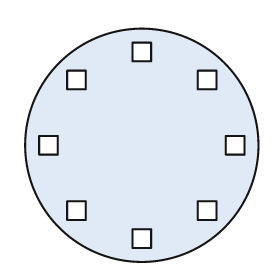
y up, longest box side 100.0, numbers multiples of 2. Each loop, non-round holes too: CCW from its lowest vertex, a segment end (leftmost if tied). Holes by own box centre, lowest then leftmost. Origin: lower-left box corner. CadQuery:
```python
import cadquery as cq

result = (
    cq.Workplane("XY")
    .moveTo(50.0, 50.0)
    .circle(50.0)
    .moveTo(46.0, 6.0)
    .lineTo(54.0, 6.0)
    .lineTo(54.0, 14.0)
    .lineTo(46.0, 14.0)
    .close()
    .moveTo(18.0, 18.0)
    .lineTo(26.0, 18.0)
    .lineTo(26.0, 26.0)
    .lineTo(18.0, 26.0)
    .close()
    .moveTo(74.0, 18.0)
    .lineTo(82.0, 18.0)
    .lineTo(82.0, 26.0)
    .lineTo(74.0, 26.0)
    .close()
    .moveTo(6.0, 46.0)
    .lineTo(14.0, 46.0)
    .lineTo(14.0, 54.0)
    .lineTo(6.0, 54.0)
    .close()
    .moveTo(86.0, 46.0)
    .lineTo(94.0, 46.0)
    .lineTo(94.0, 54.0)
    .lineTo(86.0, 54.0)
    .close()
    .moveTo(18.0, 74.0)
    .lineTo(26.0, 74.0)
    .lineTo(26.0, 82.0)
    .lineTo(18.0, 82.0)
    .close()
    .moveTo(74.0, 74.0)
    .lineTo(82.0, 74.0)
    .lineTo(82.0, 82.0)
    .lineTo(74.0, 82.0)
    .close()
    .moveTo(46.0, 86.0)
    .lineTo(54.0, 86.0)
    .lineTo(54.0, 94.0)
    .lineTo(46.0, 94.0)
    .close()
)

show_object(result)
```